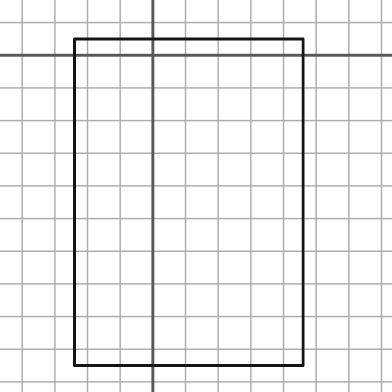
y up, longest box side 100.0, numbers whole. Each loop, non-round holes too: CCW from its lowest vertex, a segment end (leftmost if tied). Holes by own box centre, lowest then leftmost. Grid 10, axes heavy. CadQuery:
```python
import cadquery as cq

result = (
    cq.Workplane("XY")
    .moveTo(-24.0, -95.0)
    .lineTo(46.0, -95.0)
    .lineTo(46.0, 5.0)
    .lineTo(-24.0, 5.0)
    .close()
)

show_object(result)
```